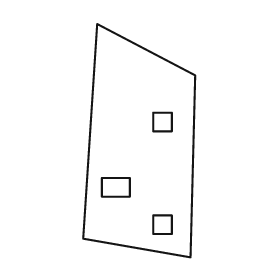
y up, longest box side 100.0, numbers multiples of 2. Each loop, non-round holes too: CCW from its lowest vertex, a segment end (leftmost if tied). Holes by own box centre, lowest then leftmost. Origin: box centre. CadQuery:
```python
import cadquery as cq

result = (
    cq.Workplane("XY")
    .moveTo(22.0, -50.0)
    .lineTo(24.0, 28.0)
    .lineTo(-18.0, 50.0)
    .lineTo(-24.0, -42.0)
    .close()
    .moveTo(6.0, -40.0)
    .lineTo(14.0, -40.0)
    .lineTo(14.0, -32.0)
    .lineTo(6.0, -32.0)
    .close()
    .moveTo(-16.0, -24.0)
    .lineTo(-4.0, -24.0)
    .lineTo(-4.0, -16.0)
    .lineTo(-16.0, -16.0)
    .close()
    .moveTo(6.0, 4.0)
    .lineTo(14.0, 4.0)
    .lineTo(14.0, 12.0)
    .lineTo(6.0, 12.0)
    .close()
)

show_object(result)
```